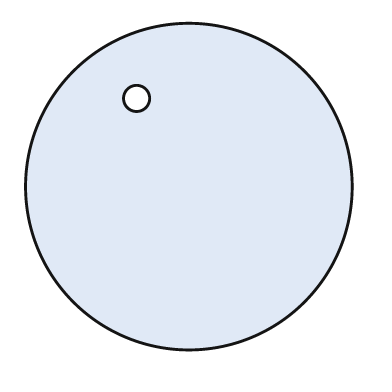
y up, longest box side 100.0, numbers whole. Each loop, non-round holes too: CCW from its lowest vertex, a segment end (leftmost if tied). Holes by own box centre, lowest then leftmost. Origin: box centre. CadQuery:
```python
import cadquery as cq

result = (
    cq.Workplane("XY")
    .moveTo(0.0, 0.0)
    .circle(50.0)
    .moveTo(-16.0, 27.0)
    .circle(4.0)
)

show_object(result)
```